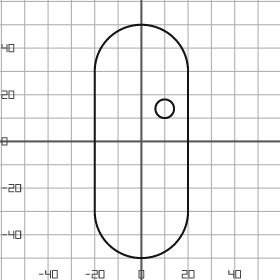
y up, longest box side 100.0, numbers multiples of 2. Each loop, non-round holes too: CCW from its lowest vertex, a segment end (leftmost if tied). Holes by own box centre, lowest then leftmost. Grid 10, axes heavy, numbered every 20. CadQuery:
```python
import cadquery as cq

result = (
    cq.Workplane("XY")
    .moveTo(-20.0, -30.0)
    .threePointArc((0.0, -50.0), (20.0, -30.0))
    .lineTo(20.0, 30.0)
    .threePointArc((0.0, 50.0), (-20.0, 30.0))
    .close()
    .moveTo(10.0, 14.0)
    .circle(4.0)
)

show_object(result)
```